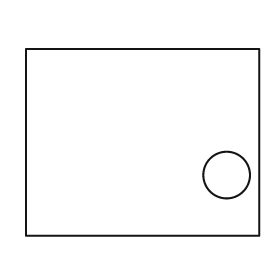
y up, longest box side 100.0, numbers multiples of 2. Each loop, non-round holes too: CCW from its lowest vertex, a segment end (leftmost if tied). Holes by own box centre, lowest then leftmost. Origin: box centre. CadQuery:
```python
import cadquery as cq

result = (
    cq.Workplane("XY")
    .moveTo(-50.0, -40.0)
    .lineTo(50.0, -40.0)
    .lineTo(50.0, 40.0)
    .lineTo(-50.0, 40.0)
    .close()
    .moveTo(36.0, -14.0)
    .circle(10.0)
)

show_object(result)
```